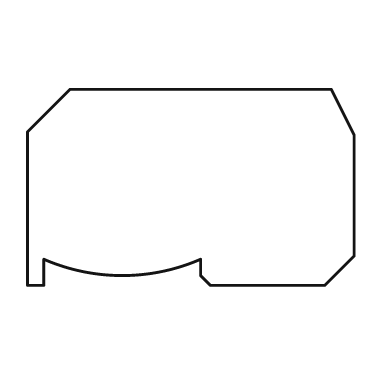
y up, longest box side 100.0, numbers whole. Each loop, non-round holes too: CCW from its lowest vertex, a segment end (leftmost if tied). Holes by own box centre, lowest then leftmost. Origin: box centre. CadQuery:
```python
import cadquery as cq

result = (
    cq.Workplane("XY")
    .moveTo(-50.0, -30.0)
    .lineTo(-45.0, -30.0)
    .lineTo(-45.0, -22.0)
    .threePointArc((-21.0, -27.0), (3.0, -22.0))
    .lineTo(3.0, -27.0)
    .lineTo(6.0, -30.0)
    .lineTo(41.0, -30.0)
    .lineTo(50.0, -21.0)
    .lineTo(50.0, 16.0)
    .lineTo(43.0, 30.0)
    .lineTo(-37.0, 30.0)
    .lineTo(-50.0, 17.0)
    .close()
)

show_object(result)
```